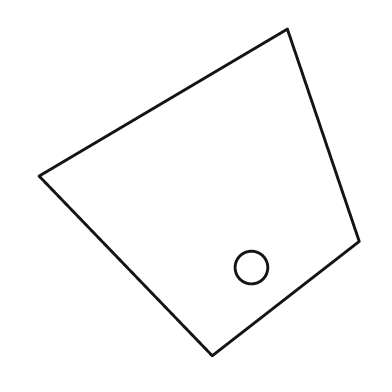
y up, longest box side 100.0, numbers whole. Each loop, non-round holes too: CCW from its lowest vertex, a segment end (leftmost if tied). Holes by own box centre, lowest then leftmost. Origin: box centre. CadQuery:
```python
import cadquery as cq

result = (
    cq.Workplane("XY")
    .moveTo(4.0, -50.0)
    .lineTo(49.0, -15.0)
    .lineTo(27.0, 50.0)
    .lineTo(-49.0, 5.0)
    .close()
    .moveTo(16.0, -23.0)
    .circle(5.0)
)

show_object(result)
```